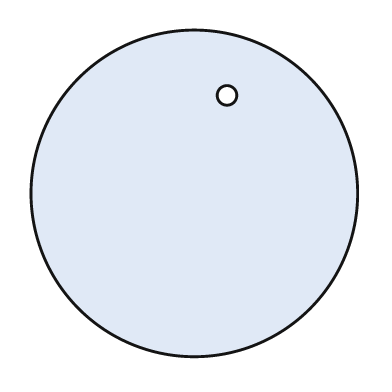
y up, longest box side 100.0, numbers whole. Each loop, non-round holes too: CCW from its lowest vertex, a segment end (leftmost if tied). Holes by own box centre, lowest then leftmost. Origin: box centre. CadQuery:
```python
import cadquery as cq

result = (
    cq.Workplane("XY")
    .moveTo(0.0, 0.0)
    .circle(50.0)
    .moveTo(10.0, 30.0)
    .circle(3.0)
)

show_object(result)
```